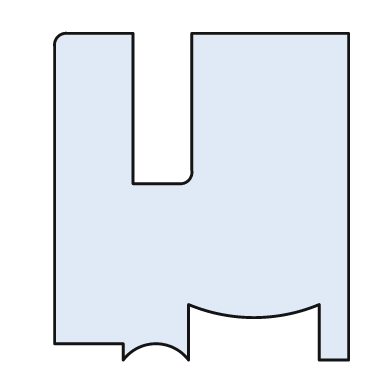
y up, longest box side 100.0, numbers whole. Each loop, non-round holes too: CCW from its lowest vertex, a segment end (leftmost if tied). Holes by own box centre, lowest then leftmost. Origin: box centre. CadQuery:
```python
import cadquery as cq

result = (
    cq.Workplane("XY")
    .moveTo(-24.0, -50.0)
    .threePointArc((-14.0, -45.0), (-4.0, -50.0))
    .lineTo(-4.0, -33.0)
    .threePointArc((16.0, -37.0), (36.0, -33.0))
    .lineTo(36.0, -50.0)
    .lineTo(45.0, -50.0)
    .lineTo(45.0, 50.0)
    .lineTo(-3.0, 50.0)
    .lineTo(-3.0, 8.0)
    .threePointArc((-4.0, 5.0), (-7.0, 4.0))
    .lineTo(-21.0, 4.0)
    .lineTo(-21.0, 50.0)
    .lineTo(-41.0, 50.0)
    .threePointArc((-44.0, 49.0), (-45.0, 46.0))
    .lineTo(-45.0, -45.0)
    .lineTo(-24.0, -45.0)
    .close()
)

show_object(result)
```